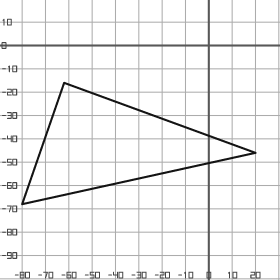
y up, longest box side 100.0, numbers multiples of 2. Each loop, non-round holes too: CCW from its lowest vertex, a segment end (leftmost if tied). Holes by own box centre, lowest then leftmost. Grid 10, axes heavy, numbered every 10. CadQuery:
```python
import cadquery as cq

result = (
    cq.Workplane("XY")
    .moveTo(-80.0, -68.0)
    .lineTo(20.0, -46.0)
    .lineTo(-62.0, -16.0)
    .close()
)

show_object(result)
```